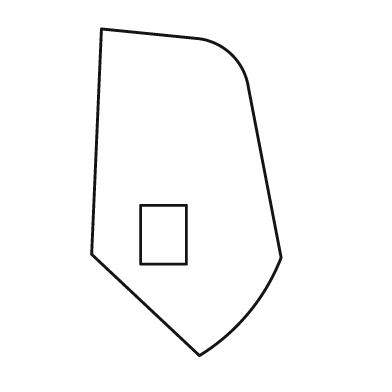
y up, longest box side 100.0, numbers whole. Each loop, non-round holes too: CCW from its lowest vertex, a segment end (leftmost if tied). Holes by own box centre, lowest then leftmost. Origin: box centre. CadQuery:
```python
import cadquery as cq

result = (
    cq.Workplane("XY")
    .moveTo(4.0, -50.0)
    .threePointArc((19.0, -37.0), (29.0, -20.0))
    .lineTo(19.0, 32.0)
    .threePointArc((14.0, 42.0), (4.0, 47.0))
    .lineTo(-26.0, 50.0)
    .lineTo(-29.0, -19.0)
    .close()
    .moveTo(-14.0, -22.0)
    .lineTo(0.0, -22.0)
    .lineTo(0.0, -4.0)
    .lineTo(-14.0, -4.0)
    .close()
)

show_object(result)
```